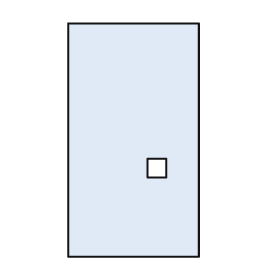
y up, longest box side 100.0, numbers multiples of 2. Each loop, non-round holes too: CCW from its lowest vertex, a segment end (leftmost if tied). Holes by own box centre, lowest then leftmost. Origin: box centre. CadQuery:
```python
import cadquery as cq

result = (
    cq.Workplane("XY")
    .moveTo(-28.0, -50.0)
    .lineTo(28.0, -50.0)
    .lineTo(28.0, 50.0)
    .lineTo(-28.0, 50.0)
    .close()
    .moveTo(6.0, -16.0)
    .lineTo(14.0, -16.0)
    .lineTo(14.0, -8.0)
    .lineTo(6.0, -8.0)
    .close()
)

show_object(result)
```